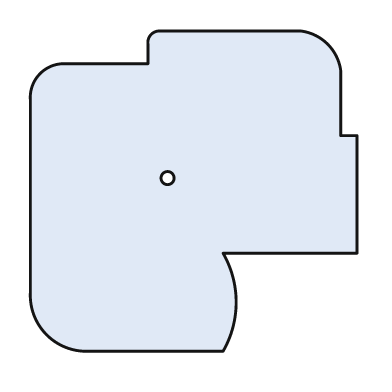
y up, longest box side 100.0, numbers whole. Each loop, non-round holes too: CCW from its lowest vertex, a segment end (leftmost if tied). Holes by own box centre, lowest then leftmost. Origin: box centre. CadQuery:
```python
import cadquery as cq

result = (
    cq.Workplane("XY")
    .moveTo(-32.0, -49.0)
    .lineTo(9.0, -49.0)
    .threePointArc((13.0, -34.0), (9.0, -19.0))
    .lineTo(50.0, -19.0)
    .lineTo(50.0, 17.0)
    .lineTo(45.0, 17.0)
    .lineTo(45.0, 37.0)
    .threePointArc((41.0, 45.0), (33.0, 49.0))
    .lineTo(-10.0, 49.0)
    .threePointArc((-13.0, 48.0), (-14.0, 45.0))
    .lineTo(-14.0, 39.0)
    .lineTo(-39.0, 39.0)
    .threePointArc((-47.0, 36.0), (-50.0, 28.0))
    .lineTo(-50.0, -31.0)
    .threePointArc((-45.0, -44.0), (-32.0, -49.0))
    .close()
    .moveTo(-8.0, 4.0)
    .circle(2.0)
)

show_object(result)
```